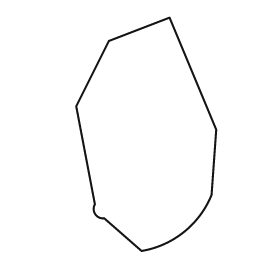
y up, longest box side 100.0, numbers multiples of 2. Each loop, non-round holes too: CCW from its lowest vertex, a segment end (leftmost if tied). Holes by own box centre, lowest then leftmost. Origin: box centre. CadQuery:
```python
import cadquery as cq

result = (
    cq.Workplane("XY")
    .moveTo(-2.0, -50.0)
    .threePointArc((16.0, -42.0), (28.0, -26.0))
    .lineTo(30.0, 2.0)
    .lineTo(10.0, 50.0)
    .lineTo(-16.0, 40.0)
    .lineTo(-30.0, 12.0)
    .lineTo(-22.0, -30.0)
    .threePointArc((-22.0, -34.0), (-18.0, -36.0))
    .close()
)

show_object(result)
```